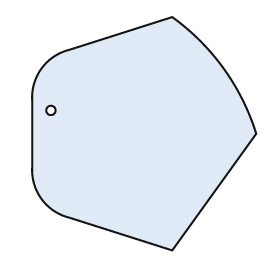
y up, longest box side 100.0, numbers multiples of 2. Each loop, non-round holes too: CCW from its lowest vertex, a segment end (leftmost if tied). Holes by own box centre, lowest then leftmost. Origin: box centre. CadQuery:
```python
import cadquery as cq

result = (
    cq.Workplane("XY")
    .moveTo(12.0, -50.0)
    .lineTo(48.0, 0.0)
    .threePointArc((34.0, 28.0), (12.0, 50.0))
    .lineTo(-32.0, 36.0)
    .threePointArc((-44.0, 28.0), (-48.0, 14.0))
    .lineTo(-48.0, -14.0)
    .threePointArc((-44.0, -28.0), (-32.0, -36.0))
    .close()
    .moveTo(-40.0, 10.0)
    .circle(2.0)
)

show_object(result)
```